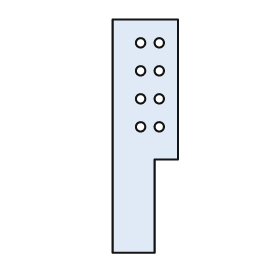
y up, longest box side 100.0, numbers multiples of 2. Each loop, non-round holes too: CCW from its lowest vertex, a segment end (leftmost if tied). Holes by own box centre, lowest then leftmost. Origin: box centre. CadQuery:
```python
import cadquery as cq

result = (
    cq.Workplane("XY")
    .moveTo(-14.0, -50.0)
    .lineTo(4.0, -50.0)
    .lineTo(4.0, -10.0)
    .lineTo(14.0, -10.0)
    .lineTo(14.0, 50.0)
    .lineTo(-14.0, 50.0)
    .close()
    .moveTo(-2.0, 4.0)
    .circle(2.0)
    .moveTo(6.0, 4.0)
    .circle(2.0)
    .moveTo(-2.0, 16.0)
    .circle(2.0)
    .moveTo(6.0, 16.0)
    .circle(2.0)
    .moveTo(-2.0, 28.0)
    .circle(2.0)
    .moveTo(6.0, 28.0)
    .circle(2.0)
    .moveTo(-2.0, 40.0)
    .circle(2.0)
    .moveTo(6.0, 40.0)
    .circle(2.0)
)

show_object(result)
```